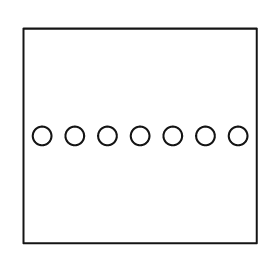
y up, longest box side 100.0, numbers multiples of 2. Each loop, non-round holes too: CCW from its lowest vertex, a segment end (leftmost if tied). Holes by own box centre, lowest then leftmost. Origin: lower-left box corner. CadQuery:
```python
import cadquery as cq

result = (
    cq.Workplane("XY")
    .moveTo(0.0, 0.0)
    .lineTo(100.0, 0.0)
    .lineTo(100.0, 92.0)
    .lineTo(0.0, 92.0)
    .close()
    .moveTo(8.0, 46.0)
    .circle(4.0)
    .moveTo(22.0, 46.0)
    .circle(4.0)
    .moveTo(36.0, 46.0)
    .circle(4.0)
    .moveTo(50.0, 46.0)
    .circle(4.0)
    .moveTo(64.0, 46.0)
    .circle(4.0)
    .moveTo(78.0, 46.0)
    .circle(4.0)
    .moveTo(92.0, 46.0)
    .circle(4.0)
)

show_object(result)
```